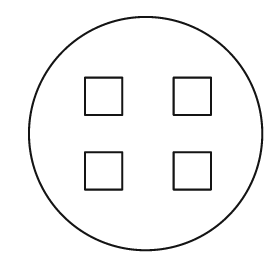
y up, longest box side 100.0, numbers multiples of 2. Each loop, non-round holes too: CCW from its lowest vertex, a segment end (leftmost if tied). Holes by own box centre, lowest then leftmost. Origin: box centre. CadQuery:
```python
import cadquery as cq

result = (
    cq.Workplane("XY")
    .moveTo(0.0, 0.0)
    .circle(50.0)
    .moveTo(-26.0, -24.0)
    .lineTo(-10.0, -24.0)
    .lineTo(-10.0, -8.0)
    .lineTo(-26.0, -8.0)
    .close()
    .moveTo(12.0, -24.0)
    .lineTo(28.0, -24.0)
    .lineTo(28.0, -8.0)
    .lineTo(12.0, -8.0)
    .close()
    .moveTo(-26.0, 8.0)
    .lineTo(-10.0, 8.0)
    .lineTo(-10.0, 24.0)
    .lineTo(-26.0, 24.0)
    .close()
    .moveTo(12.0, 8.0)
    .lineTo(28.0, 8.0)
    .lineTo(28.0, 24.0)
    .lineTo(12.0, 24.0)
    .close()
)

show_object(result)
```